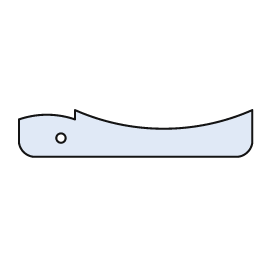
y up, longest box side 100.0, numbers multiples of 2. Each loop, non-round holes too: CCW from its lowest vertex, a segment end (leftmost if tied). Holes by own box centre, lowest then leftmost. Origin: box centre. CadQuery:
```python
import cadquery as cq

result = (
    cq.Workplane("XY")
    .moveTo(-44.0, -10.0)
    .lineTo(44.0, -10.0)
    .threePointArc((48.0, -8.0), (50.0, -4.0))
    .lineTo(50.0, 10.0)
    .threePointArc((12.0, 2.0), (-26.0, 10.0))
    .lineTo(-26.0, 6.0)
    .threePointArc((-38.0, 8.0), (-50.0, 6.0))
    .lineTo(-50.0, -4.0)
    .threePointArc((-48.0, -8.0), (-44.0, -10.0))
    .close()
    .moveTo(-32.0, -2.0)
    .circle(2.0)
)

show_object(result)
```